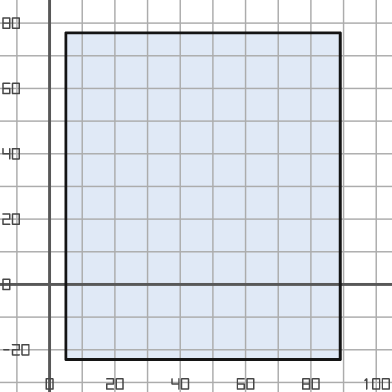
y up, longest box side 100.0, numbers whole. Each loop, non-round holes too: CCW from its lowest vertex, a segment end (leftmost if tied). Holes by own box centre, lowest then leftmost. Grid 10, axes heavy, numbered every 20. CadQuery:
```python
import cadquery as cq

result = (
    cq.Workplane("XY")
    .moveTo(5.0, -23.0)
    .lineTo(89.0, -23.0)
    .lineTo(89.0, 77.0)
    .lineTo(5.0, 77.0)
    .close()
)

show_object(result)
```